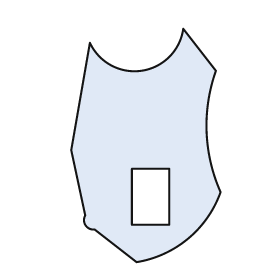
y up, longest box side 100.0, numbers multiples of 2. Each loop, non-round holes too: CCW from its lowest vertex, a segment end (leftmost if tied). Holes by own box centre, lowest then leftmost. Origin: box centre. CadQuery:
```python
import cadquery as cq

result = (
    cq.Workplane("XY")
    .moveTo(-4.0, -50.0)
    .threePointArc((18.0, -40.0), (32.0, -20.0))
    .threePointArc((26.0, 6.0), (30.0, 32.0))
    .lineTo(16.0, 50.0)
    .threePointArc((-2.0, 32.0), (-24.0, 44.0))
    .lineTo(-32.0, -2.0)
    .lineTo(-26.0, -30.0)
    .threePointArc((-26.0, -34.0), (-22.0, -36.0))
    .close()
    .moveTo(-6.0, -34.0)
    .lineTo(10.0, -34.0)
    .lineTo(10.0, -10.0)
    .lineTo(-6.0, -10.0)
    .close()
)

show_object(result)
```